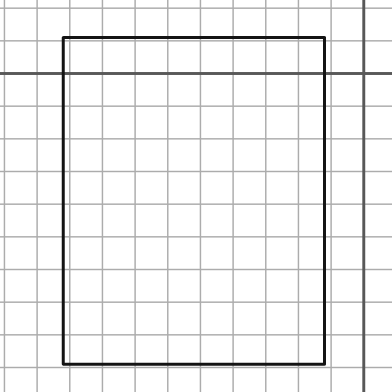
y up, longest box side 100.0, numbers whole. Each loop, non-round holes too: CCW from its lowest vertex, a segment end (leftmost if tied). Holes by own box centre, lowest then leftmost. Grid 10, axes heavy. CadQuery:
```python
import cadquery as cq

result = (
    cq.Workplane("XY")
    .moveTo(-92.0, -89.0)
    .lineTo(-12.0, -89.0)
    .lineTo(-12.0, 11.0)
    .lineTo(-92.0, 11.0)
    .close()
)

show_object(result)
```